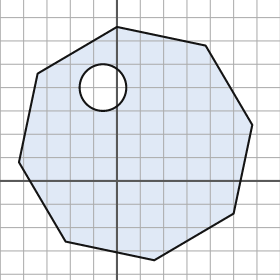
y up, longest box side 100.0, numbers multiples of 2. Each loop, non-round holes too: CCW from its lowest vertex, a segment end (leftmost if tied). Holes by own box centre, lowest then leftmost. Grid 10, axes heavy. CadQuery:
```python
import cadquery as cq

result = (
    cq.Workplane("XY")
    .moveTo(16.0, -34.0)
    .lineTo(50.0, -14.0)
    .lineTo(58.0, 24.0)
    .lineTo(38.0, 58.0)
    .lineTo(0.0, 66.0)
    .lineTo(-34.0, 46.0)
    .lineTo(-42.0, 8.0)
    .lineTo(-22.0, -26.0)
    .close()
    .moveTo(-6.0, 40.0)
    .circle(10.0)
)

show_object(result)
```